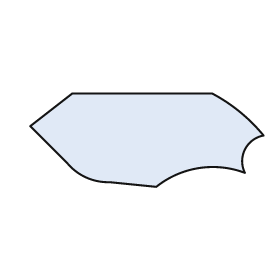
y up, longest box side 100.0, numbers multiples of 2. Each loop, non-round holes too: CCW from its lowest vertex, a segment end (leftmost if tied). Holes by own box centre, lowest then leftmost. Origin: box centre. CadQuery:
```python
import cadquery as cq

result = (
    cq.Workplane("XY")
    .moveTo(4.0, -20.0)
    .threePointArc((22.0, -12.0), (42.0, -14.0))
    .threePointArc((42.0, -4.0), (50.0, 2.0))
    .threePointArc((40.0, 12.0), (28.0, 20.0))
    .lineTo(-32.0, 20.0)
    .lineTo(-50.0, 6.0)
    .lineTo(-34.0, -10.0)
    .threePointArc((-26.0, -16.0), (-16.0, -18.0))
    .close()
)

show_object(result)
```